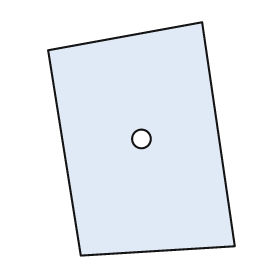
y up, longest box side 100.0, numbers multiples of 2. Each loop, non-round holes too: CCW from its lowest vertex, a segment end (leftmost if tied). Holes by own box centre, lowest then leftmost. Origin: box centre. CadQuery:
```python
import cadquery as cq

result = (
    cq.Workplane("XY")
    .moveTo(-26.0, -50.0)
    .lineTo(40.0, -46.0)
    .lineTo(26.0, 50.0)
    .lineTo(-40.0, 38.0)
    .close()
    .moveTo(0.0, 0.0)
    .circle(4.0)
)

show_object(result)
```